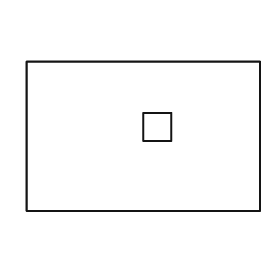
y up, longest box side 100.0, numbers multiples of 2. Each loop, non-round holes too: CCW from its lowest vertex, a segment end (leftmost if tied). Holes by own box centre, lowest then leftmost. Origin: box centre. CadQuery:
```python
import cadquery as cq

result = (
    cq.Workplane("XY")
    .moveTo(-50.0, -32.0)
    .lineTo(50.0, -32.0)
    .lineTo(50.0, 32.0)
    .lineTo(-50.0, 32.0)
    .close()
    .moveTo(0.0, -2.0)
    .lineTo(12.0, -2.0)
    .lineTo(12.0, 10.0)
    .lineTo(0.0, 10.0)
    .close()
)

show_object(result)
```